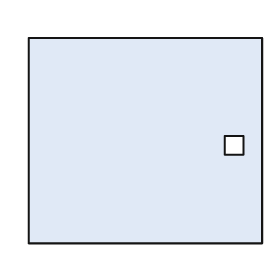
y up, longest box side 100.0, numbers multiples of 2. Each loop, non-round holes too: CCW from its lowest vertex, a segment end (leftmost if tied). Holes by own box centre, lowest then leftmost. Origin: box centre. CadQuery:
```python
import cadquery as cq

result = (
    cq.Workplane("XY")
    .moveTo(-50.0, -44.0)
    .lineTo(50.0, -44.0)
    .lineTo(50.0, 44.0)
    .lineTo(-50.0, 44.0)
    .close()
    .moveTo(34.0, -6.0)
    .lineTo(42.0, -6.0)
    .lineTo(42.0, 2.0)
    .lineTo(34.0, 2.0)
    .close()
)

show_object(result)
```